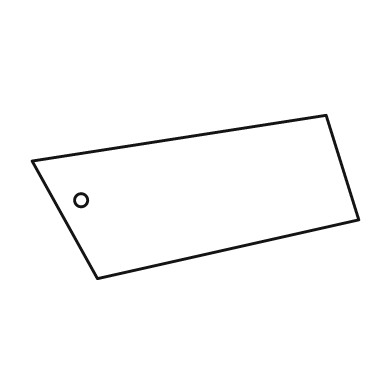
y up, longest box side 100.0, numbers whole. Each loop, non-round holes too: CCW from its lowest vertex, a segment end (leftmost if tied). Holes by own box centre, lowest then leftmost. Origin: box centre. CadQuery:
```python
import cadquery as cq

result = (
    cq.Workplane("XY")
    .moveTo(-30.0, -25.0)
    .lineTo(50.0, -7.0)
    .lineTo(40.0, 25.0)
    .lineTo(-50.0, 11.0)
    .close()
    .moveTo(-35.0, -1.0)
    .circle(2.0)
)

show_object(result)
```